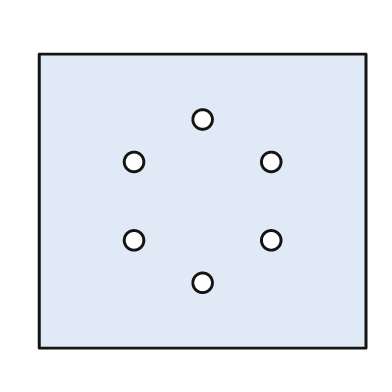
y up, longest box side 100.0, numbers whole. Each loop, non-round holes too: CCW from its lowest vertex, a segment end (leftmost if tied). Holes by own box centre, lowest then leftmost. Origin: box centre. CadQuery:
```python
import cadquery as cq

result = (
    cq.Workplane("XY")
    .moveTo(-50.0, -45.0)
    .lineTo(50.0, -45.0)
    .lineTo(50.0, 45.0)
    .lineTo(-50.0, 45.0)
    .close()
    .moveTo(0.0, -25.0)
    .circle(3.0)
    .moveTo(-21.0, -12.0)
    .circle(3.0)
    .moveTo(21.0, -12.0)
    .circle(3.0)
    .moveTo(-21.0, 12.0)
    .circle(3.0)
    .moveTo(21.0, 12.0)
    .circle(3.0)
    .moveTo(0.0, 25.0)
    .circle(3.0)
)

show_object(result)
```